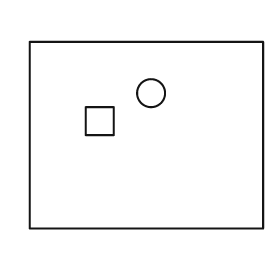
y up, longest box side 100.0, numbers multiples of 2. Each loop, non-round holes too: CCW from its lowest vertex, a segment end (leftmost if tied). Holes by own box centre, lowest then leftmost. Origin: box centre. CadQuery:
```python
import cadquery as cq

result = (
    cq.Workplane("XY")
    .moveTo(-50.0, -40.0)
    .lineTo(50.0, -40.0)
    .lineTo(50.0, 40.0)
    .lineTo(-50.0, 40.0)
    .close()
    .moveTo(-26.0, 0.0)
    .lineTo(-14.0, 0.0)
    .lineTo(-14.0, 12.0)
    .lineTo(-26.0, 12.0)
    .close()
    .moveTo(2.0, 18.0)
    .circle(6.0)
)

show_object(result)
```